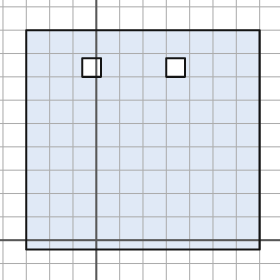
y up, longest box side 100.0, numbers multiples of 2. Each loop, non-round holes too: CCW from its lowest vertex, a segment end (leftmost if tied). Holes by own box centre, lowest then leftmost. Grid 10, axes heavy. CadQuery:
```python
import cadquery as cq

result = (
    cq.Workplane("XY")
    .moveTo(-30.0, -4.0)
    .lineTo(70.0, -4.0)
    .lineTo(70.0, 90.0)
    .lineTo(-30.0, 90.0)
    .close()
    .moveTo(-6.0, 70.0)
    .lineTo(2.0, 70.0)
    .lineTo(2.0, 78.0)
    .lineTo(-6.0, 78.0)
    .close()
    .moveTo(30.0, 70.0)
    .lineTo(38.0, 70.0)
    .lineTo(38.0, 78.0)
    .lineTo(30.0, 78.0)
    .close()
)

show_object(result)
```